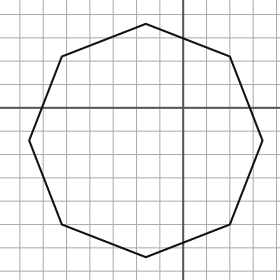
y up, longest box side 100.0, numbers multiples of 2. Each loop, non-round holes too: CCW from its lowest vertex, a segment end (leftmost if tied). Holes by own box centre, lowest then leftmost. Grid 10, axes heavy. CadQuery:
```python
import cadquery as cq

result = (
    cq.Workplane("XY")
    .moveTo(-16.0, -64.0)
    .lineTo(20.0, -50.0)
    .lineTo(34.0, -14.0)
    .lineTo(20.0, 22.0)
    .lineTo(-16.0, 36.0)
    .lineTo(-52.0, 22.0)
    .lineTo(-66.0, -14.0)
    .lineTo(-52.0, -50.0)
    .close()
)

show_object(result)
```